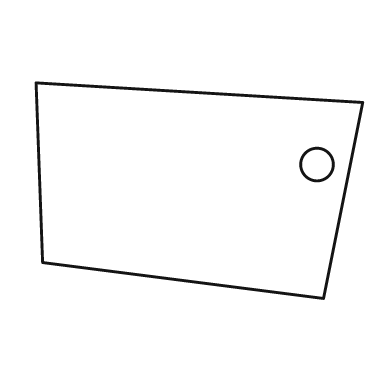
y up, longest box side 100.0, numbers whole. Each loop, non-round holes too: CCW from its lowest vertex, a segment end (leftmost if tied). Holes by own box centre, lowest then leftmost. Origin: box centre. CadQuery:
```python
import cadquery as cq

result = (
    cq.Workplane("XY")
    .moveTo(38.0, -33.0)
    .lineTo(50.0, 27.0)
    .lineTo(-50.0, 33.0)
    .lineTo(-48.0, -22.0)
    .close()
    .moveTo(36.0, 8.0)
    .circle(5.0)
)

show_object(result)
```